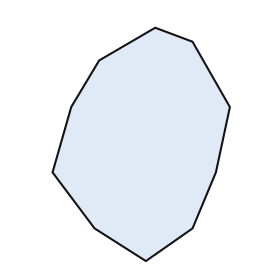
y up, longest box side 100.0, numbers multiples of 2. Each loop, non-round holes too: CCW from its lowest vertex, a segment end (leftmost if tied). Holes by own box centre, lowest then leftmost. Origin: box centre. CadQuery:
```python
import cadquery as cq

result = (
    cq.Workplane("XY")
    .moveTo(2.0, -50.0)
    .lineTo(22.0, -36.0)
    .lineTo(32.0, -12.0)
    .lineTo(38.0, 16.0)
    .lineTo(22.0, 44.0)
    .lineTo(6.0, 50.0)
    .lineTo(-18.0, 36.0)
    .lineTo(-30.0, 16.0)
    .lineTo(-38.0, -12.0)
    .lineTo(-20.0, -36.0)
    .close()
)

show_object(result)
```